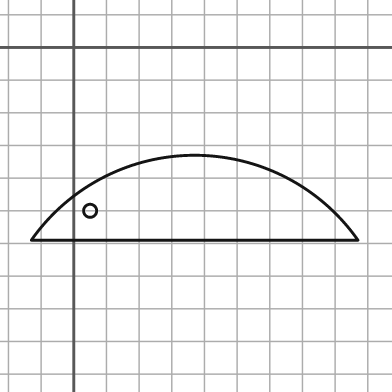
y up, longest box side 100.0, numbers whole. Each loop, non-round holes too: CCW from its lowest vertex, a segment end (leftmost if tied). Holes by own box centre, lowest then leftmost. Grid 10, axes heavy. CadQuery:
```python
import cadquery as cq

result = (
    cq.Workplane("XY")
    .moveTo(-13.0, -59.0)
    .lineTo(87.0, -59.0)
    .threePointArc((37.0, -33.0), (-13.0, -59.0))
    .close()
    .moveTo(5.0, -50.0)
    .circle(2.0)
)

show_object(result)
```